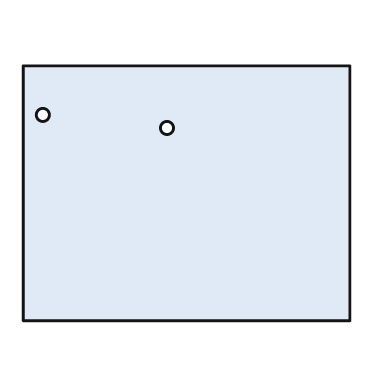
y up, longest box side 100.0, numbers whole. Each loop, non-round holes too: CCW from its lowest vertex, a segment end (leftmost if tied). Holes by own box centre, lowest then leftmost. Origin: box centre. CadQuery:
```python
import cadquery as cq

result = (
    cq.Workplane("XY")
    .moveTo(-50.0, -39.0)
    .lineTo(50.0, -39.0)
    .lineTo(50.0, 39.0)
    .lineTo(-50.0, 39.0)
    .close()
    .moveTo(-6.0, 20.0)
    .circle(2.0)
    .moveTo(-44.0, 24.0)
    .circle(2.0)
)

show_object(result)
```